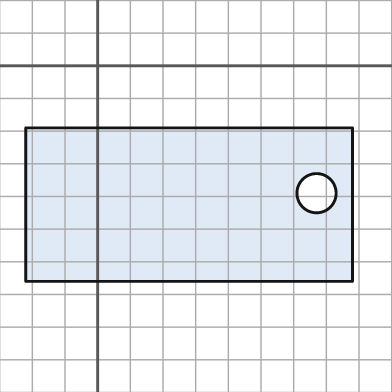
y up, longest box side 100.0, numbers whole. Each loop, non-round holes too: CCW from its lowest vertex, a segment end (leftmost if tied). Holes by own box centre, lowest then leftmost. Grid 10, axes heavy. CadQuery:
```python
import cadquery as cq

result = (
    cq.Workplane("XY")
    .moveTo(-22.0, -66.0)
    .lineTo(78.0, -66.0)
    .lineTo(78.0, -19.0)
    .lineTo(-22.0, -19.0)
    .close()
    .moveTo(67.0, -39.0)
    .circle(6.0)
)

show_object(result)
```